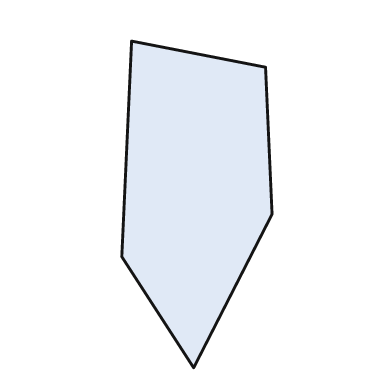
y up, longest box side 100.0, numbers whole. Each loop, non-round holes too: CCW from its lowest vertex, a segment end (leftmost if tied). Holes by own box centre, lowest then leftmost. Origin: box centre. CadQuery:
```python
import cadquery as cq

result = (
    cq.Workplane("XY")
    .moveTo(-1.0, -50.0)
    .lineTo(23.0, -3.0)
    .lineTo(21.0, 42.0)
    .lineTo(-20.0, 50.0)
    .lineTo(-23.0, -16.0)
    .close()
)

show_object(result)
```